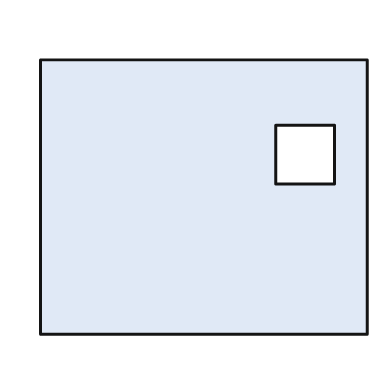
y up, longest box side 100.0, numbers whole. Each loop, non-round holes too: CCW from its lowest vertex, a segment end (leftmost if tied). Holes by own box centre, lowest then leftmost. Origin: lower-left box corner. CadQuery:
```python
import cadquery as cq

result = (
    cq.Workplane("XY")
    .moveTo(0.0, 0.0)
    .lineTo(100.0, 0.0)
    .lineTo(100.0, 84.0)
    .lineTo(0.0, 84.0)
    .close()
    .moveTo(72.0, 46.0)
    .lineTo(90.0, 46.0)
    .lineTo(90.0, 64.0)
    .lineTo(72.0, 64.0)
    .close()
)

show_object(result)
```